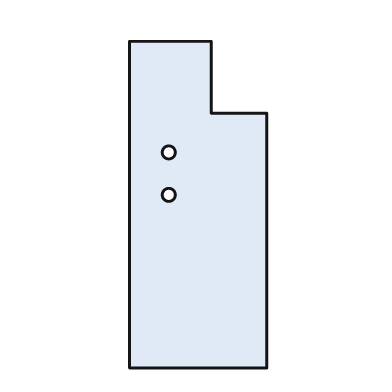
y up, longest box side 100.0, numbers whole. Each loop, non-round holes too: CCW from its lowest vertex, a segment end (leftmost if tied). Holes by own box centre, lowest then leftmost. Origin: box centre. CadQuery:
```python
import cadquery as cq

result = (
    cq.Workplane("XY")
    .moveTo(-21.0, -50.0)
    .lineTo(21.0, -50.0)
    .lineTo(21.0, 28.0)
    .lineTo(4.0, 28.0)
    .lineTo(4.0, 50.0)
    .lineTo(-21.0, 50.0)
    .close()
    .moveTo(-9.0, 3.0)
    .circle(2.0)
    .moveTo(-9.0, 16.0)
    .circle(2.0)
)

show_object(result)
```